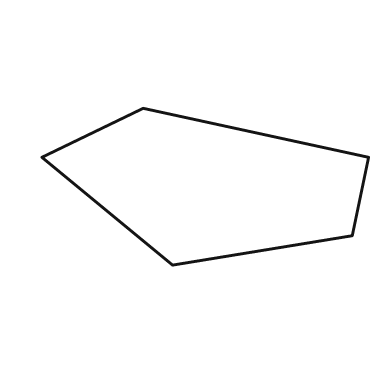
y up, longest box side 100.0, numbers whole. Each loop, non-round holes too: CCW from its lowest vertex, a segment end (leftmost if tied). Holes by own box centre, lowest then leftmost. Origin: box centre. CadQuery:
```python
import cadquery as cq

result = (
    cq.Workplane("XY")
    .moveTo(-10.0, -24.0)
    .lineTo(45.0, -15.0)
    .lineTo(50.0, 9.0)
    .lineTo(-19.0, 24.0)
    .lineTo(-50.0, 9.0)
    .close()
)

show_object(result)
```